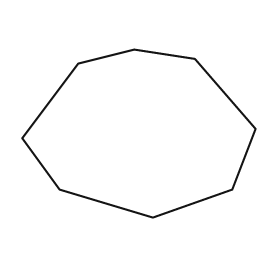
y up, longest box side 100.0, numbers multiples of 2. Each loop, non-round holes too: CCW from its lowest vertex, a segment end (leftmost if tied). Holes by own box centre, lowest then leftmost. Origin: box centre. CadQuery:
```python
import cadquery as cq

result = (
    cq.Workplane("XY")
    .moveTo(6.0, -36.0)
    .lineTo(40.0, -24.0)
    .lineTo(50.0, 2.0)
    .lineTo(24.0, 32.0)
    .lineTo(-2.0, 36.0)
    .lineTo(-26.0, 30.0)
    .lineTo(-50.0, -2.0)
    .lineTo(-34.0, -24.0)
    .close()
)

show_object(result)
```